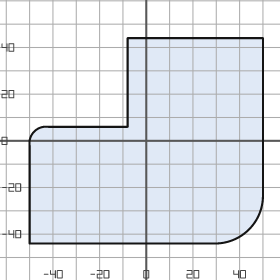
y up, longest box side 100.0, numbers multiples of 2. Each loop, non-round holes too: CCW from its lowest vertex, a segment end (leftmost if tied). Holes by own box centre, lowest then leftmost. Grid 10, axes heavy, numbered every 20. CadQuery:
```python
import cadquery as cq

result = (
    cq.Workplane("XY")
    .moveTo(-50.0, -44.0)
    .lineTo(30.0, -44.0)
    .threePointArc((44.0, -38.0), (50.0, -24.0))
    .lineTo(50.0, 44.0)
    .lineTo(-8.0, 44.0)
    .lineTo(-8.0, 6.0)
    .lineTo(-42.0, 6.0)
    .threePointArc((-48.0, 4.0), (-50.0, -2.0))
    .close()
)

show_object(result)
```